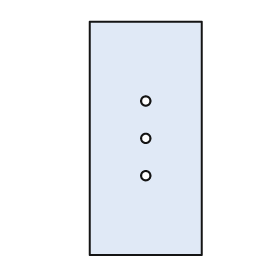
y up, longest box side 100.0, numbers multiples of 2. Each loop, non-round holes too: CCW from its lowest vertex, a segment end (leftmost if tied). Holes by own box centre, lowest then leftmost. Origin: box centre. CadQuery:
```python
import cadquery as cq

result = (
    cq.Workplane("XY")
    .moveTo(-24.0, -50.0)
    .lineTo(24.0, -50.0)
    .lineTo(24.0, 50.0)
    .lineTo(-24.0, 50.0)
    .close()
    .moveTo(0.0, -16.0)
    .circle(2.0)
    .moveTo(0.0, 0.0)
    .circle(2.0)
    .moveTo(0.0, 16.0)
    .circle(2.0)
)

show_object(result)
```